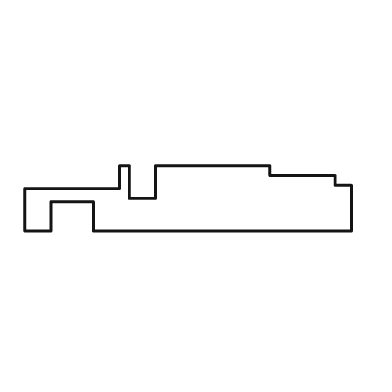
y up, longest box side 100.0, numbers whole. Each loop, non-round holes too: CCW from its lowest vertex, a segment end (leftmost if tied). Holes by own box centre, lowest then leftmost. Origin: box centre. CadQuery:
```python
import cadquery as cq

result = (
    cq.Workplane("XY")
    .moveTo(-50.0, -10.0)
    .lineTo(-42.0, -10.0)
    .lineTo(-42.0, -1.0)
    .lineTo(-29.0, -1.0)
    .lineTo(-29.0, -10.0)
    .lineTo(50.0, -10.0)
    .lineTo(50.0, 4.0)
    .lineTo(45.0, 4.0)
    .lineTo(45.0, 7.0)
    .lineTo(25.0, 7.0)
    .lineTo(25.0, 10.0)
    .lineTo(-10.0, 10.0)
    .lineTo(-10.0, 0.0)
    .lineTo(-18.0, 0.0)
    .lineTo(-18.0, 10.0)
    .lineTo(-21.0, 10.0)
    .lineTo(-21.0, 3.0)
    .lineTo(-50.0, 3.0)
    .close()
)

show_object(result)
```